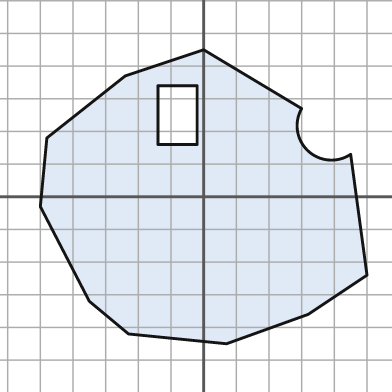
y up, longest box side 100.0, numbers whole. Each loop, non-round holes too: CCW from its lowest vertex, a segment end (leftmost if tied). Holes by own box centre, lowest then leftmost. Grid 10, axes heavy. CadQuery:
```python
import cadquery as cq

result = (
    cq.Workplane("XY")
    .moveTo(7.0, -45.0)
    .lineTo(32.0, -36.0)
    .lineTo(50.0, -24.0)
    .lineTo(45.0, 13.0)
    .threePointArc((32.0, 14.0), (30.0, 27.0))
    .lineTo(0.0, 45.0)
    .lineTo(-24.0, 37.0)
    .lineTo(-48.0, 18.0)
    .lineTo(-50.0, -3.0)
    .lineTo(-35.0, -32.0)
    .lineTo(-23.0, -42.0)
    .close()
    .moveTo(-14.0, 16.0)
    .lineTo(-2.0, 16.0)
    .lineTo(-2.0, 34.0)
    .lineTo(-14.0, 34.0)
    .close()
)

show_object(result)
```